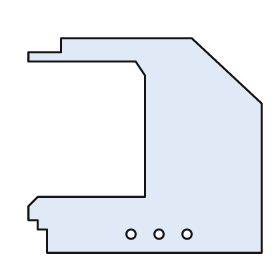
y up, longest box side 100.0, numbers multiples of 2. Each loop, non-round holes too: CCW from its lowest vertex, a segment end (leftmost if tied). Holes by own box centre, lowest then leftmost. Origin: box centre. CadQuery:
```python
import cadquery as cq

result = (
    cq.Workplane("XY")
    .moveTo(-42.0, -46.0)
    .lineTo(50.0, -46.0)
    .lineTo(50.0, 18.0)
    .lineTo(20.0, 46.0)
    .lineTo(-36.0, 46.0)
    .lineTo(-36.0, 40.0)
    .lineTo(-50.0, 40.0)
    .lineTo(-50.0, 36.0)
    .lineTo(-4.0, 36.0)
    .lineTo(0.0, 30.0)
    .lineTo(0.0, -22.0)
    .lineTo(-46.0, -22.0)
    .lineTo(-50.0, -26.0)
    .lineTo(-50.0, -32.0)
    .lineTo(-46.0, -32.0)
    .lineTo(-46.0, -36.0)
    .lineTo(-42.0, -36.0)
    .close()
    .moveTo(-6.0, -38.0)
    .circle(2.0)
    .moveTo(6.0, -38.0)
    .circle(2.0)
    .moveTo(18.0, -38.0)
    .circle(2.0)
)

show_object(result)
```